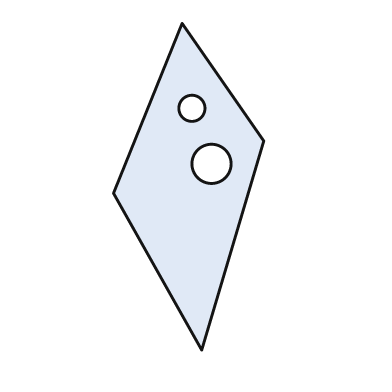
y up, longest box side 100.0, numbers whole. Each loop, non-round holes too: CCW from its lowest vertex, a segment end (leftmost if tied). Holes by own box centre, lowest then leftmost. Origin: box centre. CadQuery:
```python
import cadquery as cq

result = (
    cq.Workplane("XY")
    .moveTo(4.0, -50.0)
    .lineTo(23.0, 14.0)
    .lineTo(-2.0, 50.0)
    .lineTo(-23.0, -2.0)
    .close()
    .moveTo(7.0, 7.0)
    .circle(6.0)
    .moveTo(1.0, 24.0)
    .circle(4.0)
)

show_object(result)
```